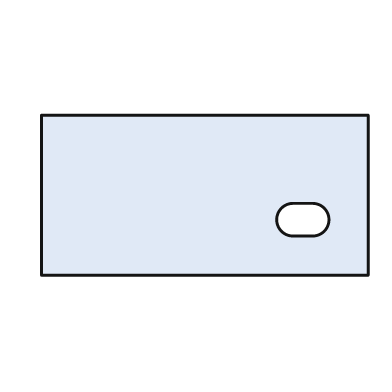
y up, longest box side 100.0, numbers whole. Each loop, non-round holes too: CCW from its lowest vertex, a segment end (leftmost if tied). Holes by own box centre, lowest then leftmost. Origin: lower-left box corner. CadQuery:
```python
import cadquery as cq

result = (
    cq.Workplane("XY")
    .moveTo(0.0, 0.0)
    .lineTo(100.0, 0.0)
    .lineTo(100.0, 49.0)
    .lineTo(0.0, 49.0)
    .close()
    .moveTo(77.0, 12.0)
    .lineTo(83.0, 12.0)
    .threePointArc((88.0, 17.0), (83.0, 22.0))
    .lineTo(77.0, 22.0)
    .threePointArc((72.0, 17.0), (77.0, 12.0))
    .close()
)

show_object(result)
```